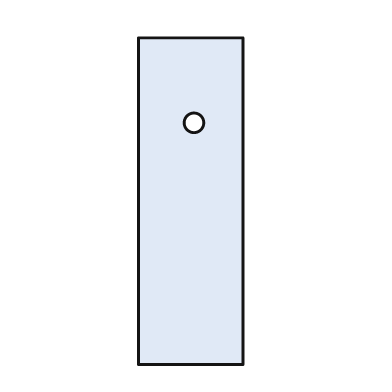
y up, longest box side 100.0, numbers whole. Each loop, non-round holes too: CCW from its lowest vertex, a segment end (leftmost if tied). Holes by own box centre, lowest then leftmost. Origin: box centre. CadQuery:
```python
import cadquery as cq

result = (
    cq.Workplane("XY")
    .moveTo(-16.0, -50.0)
    .lineTo(16.0, -50.0)
    .lineTo(16.0, 50.0)
    .lineTo(-16.0, 50.0)
    .close()
    .moveTo(1.0, 24.0)
    .circle(3.0)
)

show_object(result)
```